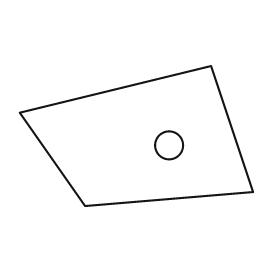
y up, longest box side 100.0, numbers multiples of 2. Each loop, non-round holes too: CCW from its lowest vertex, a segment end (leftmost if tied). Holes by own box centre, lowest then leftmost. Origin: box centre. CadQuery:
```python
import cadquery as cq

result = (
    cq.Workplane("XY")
    .moveTo(-22.0, -30.0)
    .lineTo(50.0, -24.0)
    .lineTo(32.0, 30.0)
    .lineTo(-50.0, 10.0)
    .close()
    .moveTo(14.0, -4.0)
    .circle(6.0)
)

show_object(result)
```